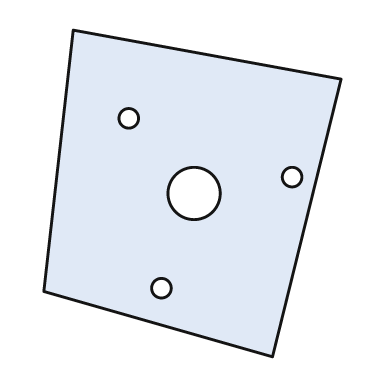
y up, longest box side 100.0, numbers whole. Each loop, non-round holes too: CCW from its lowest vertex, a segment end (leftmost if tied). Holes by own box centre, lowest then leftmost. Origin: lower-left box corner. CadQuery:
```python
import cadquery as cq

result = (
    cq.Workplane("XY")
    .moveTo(70.0, 0.0)
    .lineTo(91.0, 85.0)
    .lineTo(9.0, 100.0)
    .lineTo(0.0, 20.0)
    .close()
    .moveTo(36.0, 21.0)
    .circle(3.0)
    .moveTo(46.0, 50.0)
    .circle(8.0)
    .moveTo(76.0, 55.0)
    .circle(3.0)
    .moveTo(26.0, 73.0)
    .circle(3.0)
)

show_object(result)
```